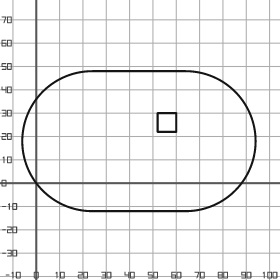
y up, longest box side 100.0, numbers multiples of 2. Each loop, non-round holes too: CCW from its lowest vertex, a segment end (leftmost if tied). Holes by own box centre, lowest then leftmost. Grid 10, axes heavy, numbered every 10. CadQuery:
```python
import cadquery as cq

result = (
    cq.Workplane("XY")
    .moveTo(24.0, -12.0)
    .lineTo(64.0, -12.0)
    .threePointArc((94.0, 18.0), (64.0, 48.0))
    .lineTo(24.0, 48.0)
    .threePointArc((-6.0, 18.0), (24.0, -12.0))
    .close()
    .moveTo(52.0, 22.0)
    .lineTo(60.0, 22.0)
    .lineTo(60.0, 30.0)
    .lineTo(52.0, 30.0)
    .close()
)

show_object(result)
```